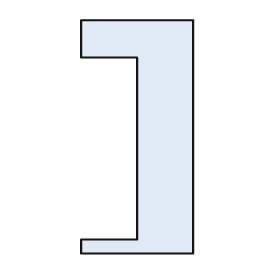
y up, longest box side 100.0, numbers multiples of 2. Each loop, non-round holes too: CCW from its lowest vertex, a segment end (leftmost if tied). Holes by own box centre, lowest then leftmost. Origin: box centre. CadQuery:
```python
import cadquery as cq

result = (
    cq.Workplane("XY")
    .moveTo(-24.0, -50.0)
    .lineTo(24.0, -50.0)
    .lineTo(24.0, 50.0)
    .lineTo(-24.0, 50.0)
    .lineTo(-24.0, 34.0)
    .lineTo(0.0, 34.0)
    .lineTo(0.0, -44.0)
    .lineTo(-24.0, -44.0)
    .close()
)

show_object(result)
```